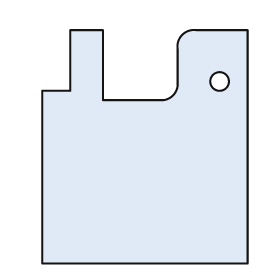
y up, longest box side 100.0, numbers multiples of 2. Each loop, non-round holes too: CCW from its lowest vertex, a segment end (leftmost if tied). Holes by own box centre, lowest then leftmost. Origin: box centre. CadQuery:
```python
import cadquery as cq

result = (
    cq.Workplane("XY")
    .moveTo(-44.0, -50.0)
    .lineTo(44.0, -50.0)
    .lineTo(44.0, 50.0)
    .lineTo(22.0, 50.0)
    .threePointArc((16.0, 48.0), (14.0, 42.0))
    .lineTo(14.0, 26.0)
    .threePointArc((12.0, 22.0), (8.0, 20.0))
    .lineTo(-18.0, 20.0)
    .lineTo(-18.0, 50.0)
    .lineTo(-32.0, 50.0)
    .lineTo(-32.0, 24.0)
    .lineTo(-44.0, 24.0)
    .close()
    .moveTo(32.0, 28.0)
    .circle(4.0)
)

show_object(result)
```